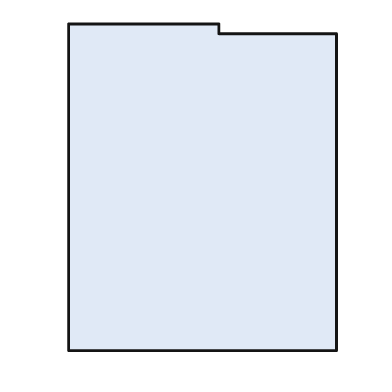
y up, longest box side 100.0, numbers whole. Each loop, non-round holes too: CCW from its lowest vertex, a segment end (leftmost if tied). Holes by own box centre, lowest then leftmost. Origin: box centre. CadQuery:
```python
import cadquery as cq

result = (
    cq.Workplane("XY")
    .moveTo(-41.0, -50.0)
    .lineTo(41.0, -50.0)
    .lineTo(41.0, 47.0)
    .lineTo(5.0, 47.0)
    .lineTo(5.0, 50.0)
    .lineTo(-41.0, 50.0)
    .close()
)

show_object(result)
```